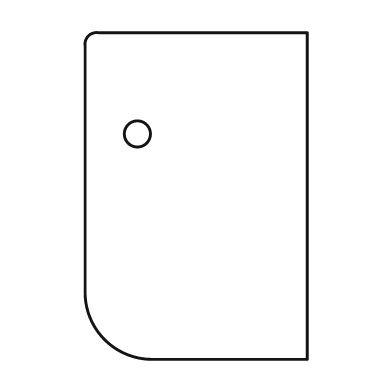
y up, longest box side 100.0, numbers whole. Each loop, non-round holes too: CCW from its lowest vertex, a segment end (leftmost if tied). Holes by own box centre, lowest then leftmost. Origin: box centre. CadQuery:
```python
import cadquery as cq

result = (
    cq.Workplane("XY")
    .moveTo(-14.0, -50.0)
    .lineTo(34.0, -50.0)
    .lineTo(34.0, 50.0)
    .lineTo(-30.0, 50.0)
    .threePointArc((-33.0, 49.0), (-34.0, 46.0))
    .lineTo(-34.0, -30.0)
    .threePointArc((-28.0, -44.0), (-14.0, -50.0))
    .close()
    .moveTo(-18.0, 19.0)
    .circle(4.0)
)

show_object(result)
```